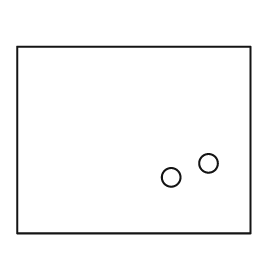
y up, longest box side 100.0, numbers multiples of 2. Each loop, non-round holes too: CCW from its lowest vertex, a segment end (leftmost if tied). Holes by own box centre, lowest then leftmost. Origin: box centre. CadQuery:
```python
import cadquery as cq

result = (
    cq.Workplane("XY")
    .moveTo(-50.0, -40.0)
    .lineTo(50.0, -40.0)
    .lineTo(50.0, 40.0)
    .lineTo(-50.0, 40.0)
    .close()
    .moveTo(16.0, -16.0)
    .circle(4.0)
    .moveTo(32.0, -10.0)
    .circle(4.0)
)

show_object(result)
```